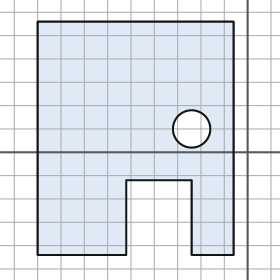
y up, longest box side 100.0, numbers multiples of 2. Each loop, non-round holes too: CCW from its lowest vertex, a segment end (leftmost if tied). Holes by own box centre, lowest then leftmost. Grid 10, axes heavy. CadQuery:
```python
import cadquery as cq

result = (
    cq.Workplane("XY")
    .moveTo(-90.0, -44.0)
    .lineTo(-52.0, -44.0)
    .lineTo(-52.0, -12.0)
    .lineTo(-24.0, -12.0)
    .lineTo(-24.0, -44.0)
    .lineTo(-6.0, -44.0)
    .lineTo(-6.0, 56.0)
    .lineTo(-90.0, 56.0)
    .close()
    .moveTo(-24.0, 10.0)
    .circle(8.0)
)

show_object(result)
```